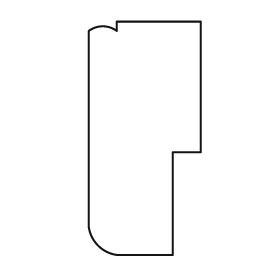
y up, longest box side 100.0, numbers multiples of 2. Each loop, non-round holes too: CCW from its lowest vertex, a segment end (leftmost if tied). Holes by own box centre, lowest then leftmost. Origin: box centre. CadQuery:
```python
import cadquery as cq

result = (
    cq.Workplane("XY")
    .moveTo(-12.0, -50.0)
    .lineTo(12.0, -50.0)
    .lineTo(12.0, -6.0)
    .lineTo(24.0, -6.0)
    .lineTo(24.0, 50.0)
    .lineTo(-12.0, 50.0)
    .lineTo(-12.0, 46.0)
    .threePointArc((-18.0, 48.0), (-24.0, 46.0))
    .lineTo(-24.0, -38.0)
    .threePointArc((-20.0, -46.0), (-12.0, -50.0))
    .close()
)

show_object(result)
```